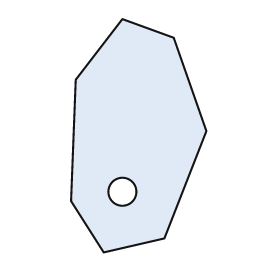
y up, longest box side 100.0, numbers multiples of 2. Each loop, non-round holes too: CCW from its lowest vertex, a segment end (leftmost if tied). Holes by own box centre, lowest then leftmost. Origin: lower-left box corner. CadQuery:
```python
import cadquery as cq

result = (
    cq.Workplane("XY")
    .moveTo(14.0, 0.0)
    .lineTo(40.0, 6.0)
    .lineTo(58.0, 52.0)
    .lineTo(44.0, 92.0)
    .lineTo(22.0, 100.0)
    .lineTo(2.0, 74.0)
    .lineTo(0.0, 22.0)
    .close()
    .moveTo(22.0, 26.0)
    .circle(6.0)
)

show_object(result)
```